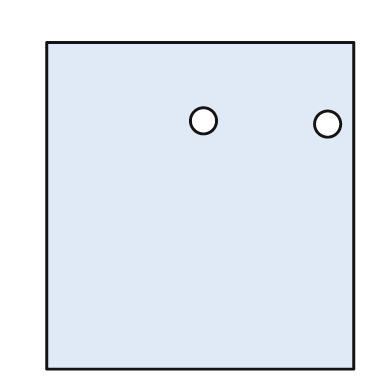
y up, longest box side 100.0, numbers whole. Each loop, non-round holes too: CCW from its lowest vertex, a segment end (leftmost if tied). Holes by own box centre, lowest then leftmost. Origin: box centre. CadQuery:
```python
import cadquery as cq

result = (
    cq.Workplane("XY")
    .moveTo(-47.0, -50.0)
    .lineTo(47.0, -50.0)
    .lineTo(47.0, 50.0)
    .lineTo(-47.0, 50.0)
    .close()
    .moveTo(39.0, 25.0)
    .circle(4.0)
    .moveTo(1.0, 26.0)
    .circle(4.0)
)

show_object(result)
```